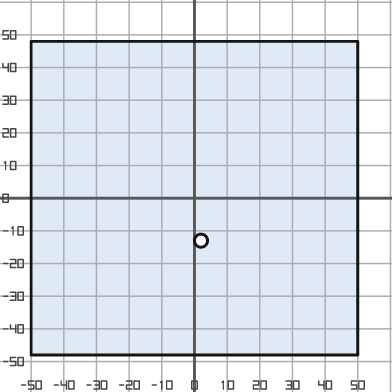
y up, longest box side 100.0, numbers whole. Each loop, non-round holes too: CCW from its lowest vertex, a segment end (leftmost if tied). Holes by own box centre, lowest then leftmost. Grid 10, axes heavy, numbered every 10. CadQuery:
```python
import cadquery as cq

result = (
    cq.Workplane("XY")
    .moveTo(-50.0, -48.0)
    .lineTo(50.0, -48.0)
    .lineTo(50.0, 48.0)
    .lineTo(-50.0, 48.0)
    .close()
    .moveTo(2.0, -13.0)
    .circle(2.0)
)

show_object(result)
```